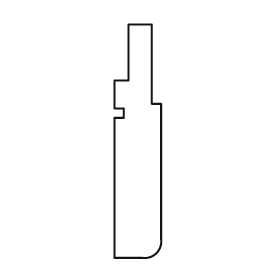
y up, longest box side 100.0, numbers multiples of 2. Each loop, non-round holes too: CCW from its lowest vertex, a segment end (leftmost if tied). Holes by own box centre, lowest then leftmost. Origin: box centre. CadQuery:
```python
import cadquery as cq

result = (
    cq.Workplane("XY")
    .moveTo(-10.0, -50.0)
    .lineTo(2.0, -50.0)
    .threePointArc((8.0, -48.0), (10.0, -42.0))
    .lineTo(10.0, 16.0)
    .lineTo(6.0, 16.0)
    .lineTo(6.0, 50.0)
    .lineTo(-4.0, 50.0)
    .lineTo(-4.0, 26.0)
    .lineTo(-10.0, 26.0)
    .lineTo(-10.0, 14.0)
    .lineTo(-6.0, 14.0)
    .lineTo(-6.0, 10.0)
    .lineTo(-10.0, 10.0)
    .close()
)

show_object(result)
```